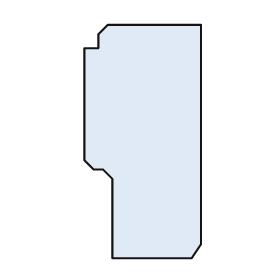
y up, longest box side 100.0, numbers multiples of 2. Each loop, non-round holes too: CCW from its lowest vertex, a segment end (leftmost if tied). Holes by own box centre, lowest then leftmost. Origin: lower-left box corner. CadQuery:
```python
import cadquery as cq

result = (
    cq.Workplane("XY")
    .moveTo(12.0, 0.0)
    .lineTo(46.0, 0.0)
    .lineTo(50.0, 6.0)
    .lineTo(50.0, 100.0)
    .lineTo(10.0, 100.0)
    .lineTo(6.0, 96.0)
    .lineTo(6.0, 90.0)
    .lineTo(0.0, 90.0)
    .lineTo(0.0, 42.0)
    .lineTo(4.0, 38.0)
    .lineTo(8.0, 38.0)
    .lineTo(12.0, 34.0)
    .close()
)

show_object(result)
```